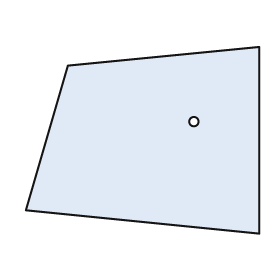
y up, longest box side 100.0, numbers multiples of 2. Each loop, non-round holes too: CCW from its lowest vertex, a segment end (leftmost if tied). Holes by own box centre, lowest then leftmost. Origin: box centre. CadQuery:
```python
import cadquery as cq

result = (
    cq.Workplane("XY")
    .moveTo(50.0, -40.0)
    .lineTo(50.0, 40.0)
    .lineTo(-32.0, 32.0)
    .lineTo(-50.0, -30.0)
    .close()
    .moveTo(22.0, 8.0)
    .circle(2.0)
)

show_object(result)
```